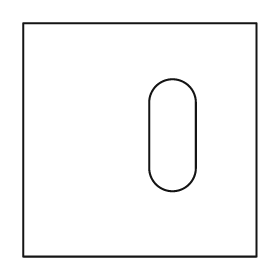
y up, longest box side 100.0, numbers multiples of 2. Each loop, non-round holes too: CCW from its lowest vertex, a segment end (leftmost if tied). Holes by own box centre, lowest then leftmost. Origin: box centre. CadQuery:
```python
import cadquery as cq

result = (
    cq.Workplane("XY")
    .moveTo(-50.0, -50.0)
    .lineTo(50.0, -50.0)
    .lineTo(50.0, 50.0)
    .lineTo(-50.0, 50.0)
    .close()
    .moveTo(4.0, -12.0)
    .threePointArc((14.0, -22.0), (24.0, -12.0))
    .lineTo(24.0, 16.0)
    .threePointArc((14.0, 26.0), (4.0, 16.0))
    .close()
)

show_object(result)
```